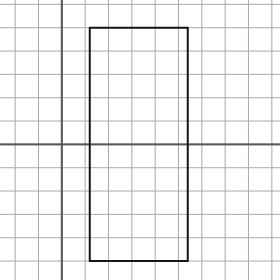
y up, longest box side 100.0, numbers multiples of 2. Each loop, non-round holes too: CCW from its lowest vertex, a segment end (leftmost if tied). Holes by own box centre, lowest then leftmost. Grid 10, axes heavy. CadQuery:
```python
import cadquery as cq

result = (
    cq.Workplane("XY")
    .moveTo(12.0, -50.0)
    .lineTo(54.0, -50.0)
    .lineTo(54.0, 50.0)
    .lineTo(12.0, 50.0)
    .close()
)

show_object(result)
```